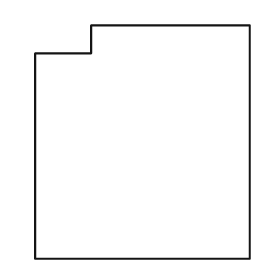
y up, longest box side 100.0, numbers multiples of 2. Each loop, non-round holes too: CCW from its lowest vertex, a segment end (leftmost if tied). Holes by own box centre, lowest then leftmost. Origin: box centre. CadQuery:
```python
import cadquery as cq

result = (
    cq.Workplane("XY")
    .moveTo(-46.0, -50.0)
    .lineTo(46.0, -50.0)
    .lineTo(46.0, 50.0)
    .lineTo(-22.0, 50.0)
    .lineTo(-22.0, 38.0)
    .lineTo(-46.0, 38.0)
    .close()
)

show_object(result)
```